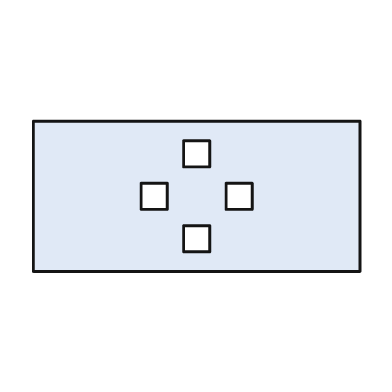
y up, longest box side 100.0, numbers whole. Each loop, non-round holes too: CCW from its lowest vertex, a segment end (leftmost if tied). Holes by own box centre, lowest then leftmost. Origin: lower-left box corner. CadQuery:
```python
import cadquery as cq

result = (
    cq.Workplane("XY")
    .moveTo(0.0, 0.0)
    .lineTo(100.0, 0.0)
    .lineTo(100.0, 46.0)
    .lineTo(0.0, 46.0)
    .close()
    .moveTo(46.0, 6.0)
    .lineTo(54.0, 6.0)
    .lineTo(54.0, 14.0)
    .lineTo(46.0, 14.0)
    .close()
    .moveTo(33.0, 19.0)
    .lineTo(41.0, 19.0)
    .lineTo(41.0, 27.0)
    .lineTo(33.0, 27.0)
    .close()
    .moveTo(59.0, 19.0)
    .lineTo(67.0, 19.0)
    .lineTo(67.0, 27.0)
    .lineTo(59.0, 27.0)
    .close()
    .moveTo(46.0, 32.0)
    .lineTo(54.0, 32.0)
    .lineTo(54.0, 40.0)
    .lineTo(46.0, 40.0)
    .close()
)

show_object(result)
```